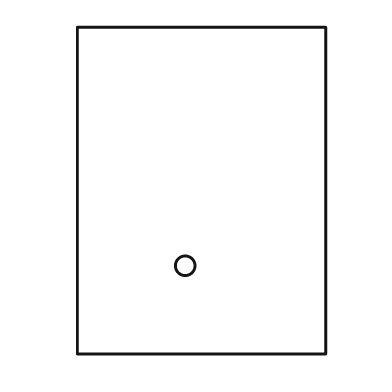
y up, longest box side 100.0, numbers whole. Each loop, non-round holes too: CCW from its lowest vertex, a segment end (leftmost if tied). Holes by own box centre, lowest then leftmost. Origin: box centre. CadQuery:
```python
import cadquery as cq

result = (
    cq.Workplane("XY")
    .moveTo(-38.0, -50.0)
    .lineTo(38.0, -50.0)
    .lineTo(38.0, 50.0)
    .lineTo(-38.0, 50.0)
    .close()
    .moveTo(-5.0, -23.0)
    .circle(3.0)
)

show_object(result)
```